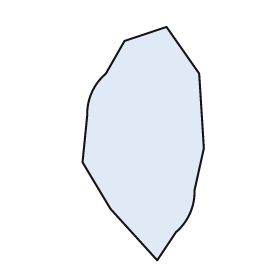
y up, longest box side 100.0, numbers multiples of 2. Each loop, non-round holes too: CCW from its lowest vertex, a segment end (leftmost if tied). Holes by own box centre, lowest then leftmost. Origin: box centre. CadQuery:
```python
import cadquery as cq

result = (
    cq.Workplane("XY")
    .moveTo(6.0, -50.0)
    .lineTo(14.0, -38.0)
    .threePointArc((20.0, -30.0), (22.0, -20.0))
    .lineTo(26.0, -2.0)
    .lineTo(24.0, 30.0)
    .lineTo(10.0, 50.0)
    .lineTo(-8.0, 44.0)
    .lineTo(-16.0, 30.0)
    .threePointArc((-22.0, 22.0), (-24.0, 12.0))
    .lineTo(-26.0, -8.0)
    .lineTo(-14.0, -28.0)
    .close()
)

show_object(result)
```